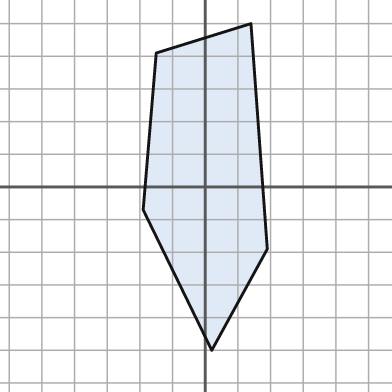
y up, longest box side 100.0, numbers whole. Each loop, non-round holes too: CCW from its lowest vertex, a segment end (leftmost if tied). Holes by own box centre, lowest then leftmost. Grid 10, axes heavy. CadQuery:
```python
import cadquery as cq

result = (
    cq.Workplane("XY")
    .moveTo(2.0, -50.0)
    .lineTo(19.0, -19.0)
    .lineTo(14.0, 50.0)
    .lineTo(-15.0, 41.0)
    .lineTo(-19.0, -7.0)
    .close()
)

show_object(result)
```